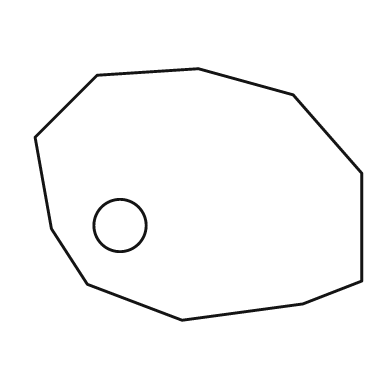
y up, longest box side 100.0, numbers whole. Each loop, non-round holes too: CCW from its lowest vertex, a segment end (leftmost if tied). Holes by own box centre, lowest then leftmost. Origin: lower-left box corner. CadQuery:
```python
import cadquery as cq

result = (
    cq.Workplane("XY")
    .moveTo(45.0, 0.0)
    .lineTo(82.0, 5.0)
    .lineTo(100.0, 12.0)
    .lineTo(100.0, 45.0)
    .lineTo(79.0, 69.0)
    .lineTo(50.0, 77.0)
    .lineTo(19.0, 75.0)
    .lineTo(0.0, 56.0)
    .lineTo(5.0, 28.0)
    .lineTo(16.0, 11.0)
    .close()
    .moveTo(26.0, 29.0)
    .circle(8.0)
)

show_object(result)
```